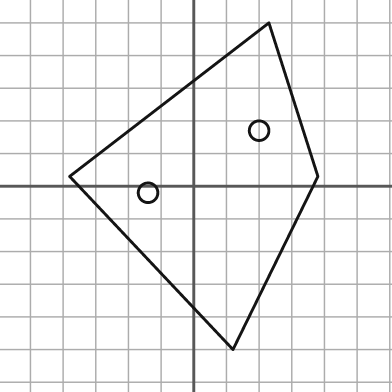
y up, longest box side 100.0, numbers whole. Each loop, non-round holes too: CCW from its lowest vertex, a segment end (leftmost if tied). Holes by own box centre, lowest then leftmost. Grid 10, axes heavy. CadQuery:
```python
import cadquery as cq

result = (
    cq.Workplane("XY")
    .moveTo(12.0, -50.0)
    .lineTo(38.0, 3.0)
    .lineTo(23.0, 50.0)
    .lineTo(-38.0, 3.0)
    .close()
    .moveTo(-14.0, -2.0)
    .circle(3.0)
    .moveTo(20.0, 17.0)
    .circle(3.0)
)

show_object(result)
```